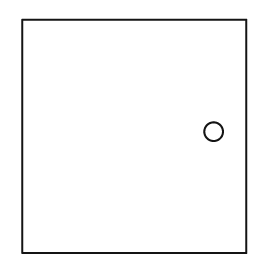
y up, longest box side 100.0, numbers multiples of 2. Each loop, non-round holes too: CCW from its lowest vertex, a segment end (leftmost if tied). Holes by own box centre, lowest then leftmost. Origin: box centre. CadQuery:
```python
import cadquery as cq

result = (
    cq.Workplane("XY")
    .moveTo(-48.0, -50.0)
    .lineTo(48.0, -50.0)
    .lineTo(48.0, 50.0)
    .lineTo(-48.0, 50.0)
    .close()
    .moveTo(34.0, 2.0)
    .circle(4.0)
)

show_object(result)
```